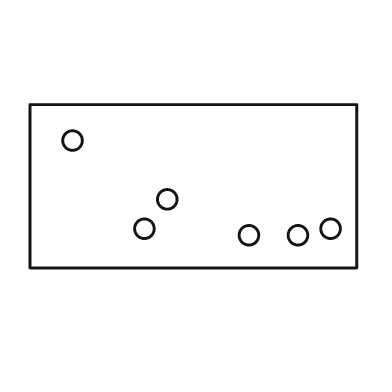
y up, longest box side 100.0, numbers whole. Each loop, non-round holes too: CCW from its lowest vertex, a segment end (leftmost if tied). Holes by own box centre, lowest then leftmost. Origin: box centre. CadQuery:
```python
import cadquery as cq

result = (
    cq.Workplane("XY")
    .moveTo(-50.0, -25.0)
    .lineTo(50.0, -25.0)
    .lineTo(50.0, 25.0)
    .lineTo(-50.0, 25.0)
    .close()
    .moveTo(17.0, -15.0)
    .circle(3.0)
    .moveTo(32.0, -15.0)
    .circle(3.0)
    .moveTo(-15.0, -13.0)
    .circle(3.0)
    .moveTo(42.0, -13.0)
    .circle(3.0)
    .moveTo(-8.0, -4.0)
    .circle(3.0)
    .moveTo(-37.0, 14.0)
    .circle(3.0)
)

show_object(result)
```